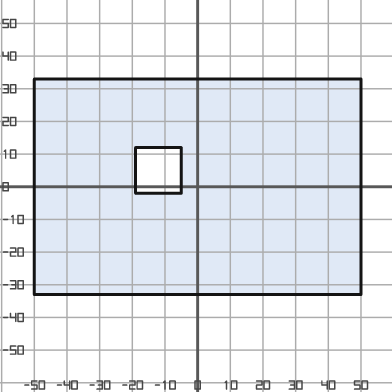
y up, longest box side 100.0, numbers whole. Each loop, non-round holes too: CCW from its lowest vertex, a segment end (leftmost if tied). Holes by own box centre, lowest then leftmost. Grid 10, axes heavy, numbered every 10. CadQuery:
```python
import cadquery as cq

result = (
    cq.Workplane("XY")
    .moveTo(-50.0, -33.0)
    .lineTo(50.0, -33.0)
    .lineTo(50.0, 33.0)
    .lineTo(-50.0, 33.0)
    .close()
    .moveTo(-19.0, -2.0)
    .lineTo(-5.0, -2.0)
    .lineTo(-5.0, 12.0)
    .lineTo(-19.0, 12.0)
    .close()
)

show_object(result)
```